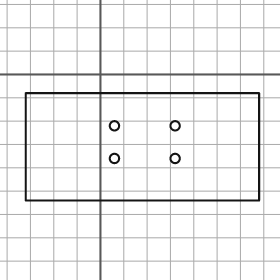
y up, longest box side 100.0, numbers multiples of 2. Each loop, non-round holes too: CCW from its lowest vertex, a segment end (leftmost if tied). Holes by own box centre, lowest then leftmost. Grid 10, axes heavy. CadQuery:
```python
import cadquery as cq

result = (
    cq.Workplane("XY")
    .moveTo(-32.0, -54.0)
    .lineTo(68.0, -54.0)
    .lineTo(68.0, -8.0)
    .lineTo(-32.0, -8.0)
    .close()
    .moveTo(6.0, -36.0)
    .circle(2.0)
    .moveTo(32.0, -36.0)
    .circle(2.0)
    .moveTo(6.0, -22.0)
    .circle(2.0)
    .moveTo(32.0, -22.0)
    .circle(2.0)
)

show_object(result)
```